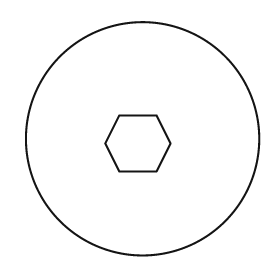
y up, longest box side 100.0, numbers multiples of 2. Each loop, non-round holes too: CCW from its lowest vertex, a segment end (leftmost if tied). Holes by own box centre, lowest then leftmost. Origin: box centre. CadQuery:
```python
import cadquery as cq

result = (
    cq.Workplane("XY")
    .moveTo(0.0, 0.0)
    .circle(50.0)
    .moveTo(-10.0, -14.0)
    .lineTo(6.0, -14.0)
    .lineTo(12.0, -2.0)
    .lineTo(6.0, 10.0)
    .lineTo(-10.0, 10.0)
    .lineTo(-16.0, -2.0)
    .close()
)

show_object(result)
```